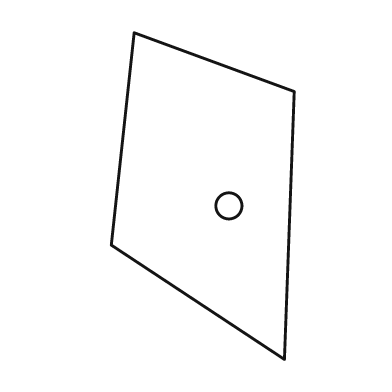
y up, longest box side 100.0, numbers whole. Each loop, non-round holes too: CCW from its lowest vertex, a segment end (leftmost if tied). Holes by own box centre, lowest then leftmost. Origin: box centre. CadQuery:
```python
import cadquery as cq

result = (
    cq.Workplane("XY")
    .moveTo(25.0, -50.0)
    .lineTo(28.0, 32.0)
    .lineTo(-21.0, 50.0)
    .lineTo(-28.0, -15.0)
    .close()
    .moveTo(8.0, -3.0)
    .circle(4.0)
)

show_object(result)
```